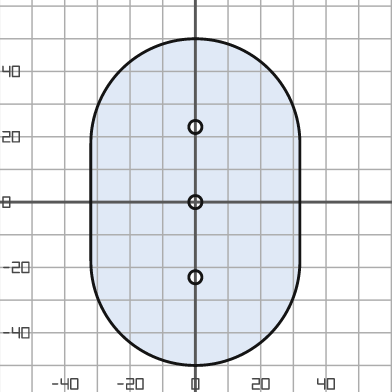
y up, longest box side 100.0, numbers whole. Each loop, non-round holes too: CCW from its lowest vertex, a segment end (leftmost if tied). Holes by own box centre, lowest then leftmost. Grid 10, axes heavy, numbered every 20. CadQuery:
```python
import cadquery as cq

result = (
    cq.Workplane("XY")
    .moveTo(-32.0, -18.0)
    .threePointArc((0.0, -50.0), (32.0, -18.0))
    .lineTo(32.0, 18.0)
    .threePointArc((0.0, 50.0), (-32.0, 18.0))
    .close()
    .moveTo(0.0, -23.0)
    .circle(2.0)
    .moveTo(0.0, 0.0)
    .circle(2.0)
    .moveTo(0.0, 23.0)
    .circle(2.0)
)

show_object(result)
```